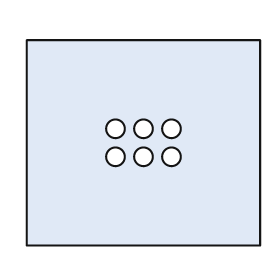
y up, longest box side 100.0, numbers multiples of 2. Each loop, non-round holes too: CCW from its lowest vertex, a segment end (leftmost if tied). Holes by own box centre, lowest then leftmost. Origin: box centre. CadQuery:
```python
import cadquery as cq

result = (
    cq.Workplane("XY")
    .moveTo(-50.0, -44.0)
    .lineTo(50.0, -44.0)
    .lineTo(50.0, 44.0)
    .lineTo(-50.0, 44.0)
    .close()
    .moveTo(-12.0, -6.0)
    .circle(4.0)
    .moveTo(0.0, -6.0)
    .circle(4.0)
    .moveTo(12.0, -6.0)
    .circle(4.0)
    .moveTo(-12.0, 6.0)
    .circle(4.0)
    .moveTo(0.0, 6.0)
    .circle(4.0)
    .moveTo(12.0, 6.0)
    .circle(4.0)
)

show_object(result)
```